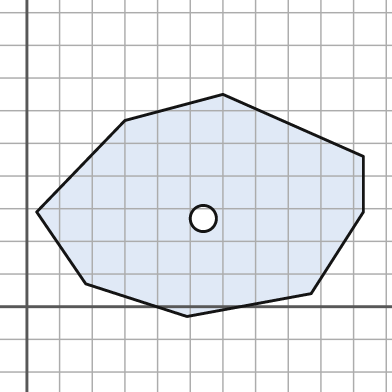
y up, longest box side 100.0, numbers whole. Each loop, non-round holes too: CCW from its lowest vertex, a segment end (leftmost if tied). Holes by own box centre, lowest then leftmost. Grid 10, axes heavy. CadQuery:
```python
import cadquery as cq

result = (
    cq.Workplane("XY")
    .moveTo(49.0, -3.0)
    .lineTo(87.0, 4.0)
    .lineTo(103.0, 29.0)
    .lineTo(103.0, 46.0)
    .lineTo(60.0, 65.0)
    .lineTo(30.0, 57.0)
    .lineTo(3.0, 29.0)
    .lineTo(18.0, 7.0)
    .close()
    .moveTo(54.0, 27.0)
    .circle(4.0)
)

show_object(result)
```